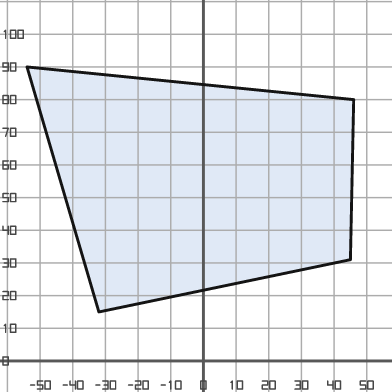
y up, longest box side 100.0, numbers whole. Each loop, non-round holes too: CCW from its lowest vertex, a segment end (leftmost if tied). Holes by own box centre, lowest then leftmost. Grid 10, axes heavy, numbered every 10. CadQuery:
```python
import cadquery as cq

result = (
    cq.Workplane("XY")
    .moveTo(-32.0, 15.0)
    .lineTo(45.0, 31.0)
    .lineTo(46.0, 80.0)
    .lineTo(-54.0, 90.0)
    .close()
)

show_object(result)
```